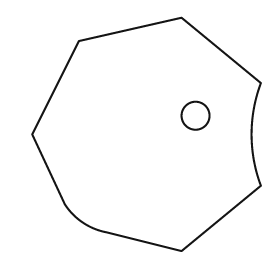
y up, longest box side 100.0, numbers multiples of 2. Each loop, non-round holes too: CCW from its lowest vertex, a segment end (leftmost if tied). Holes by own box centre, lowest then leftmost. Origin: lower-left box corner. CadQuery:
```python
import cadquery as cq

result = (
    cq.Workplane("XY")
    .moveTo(64.0, 0.0)
    .lineTo(98.0, 28.0)
    .threePointArc((94.0, 50.0), (98.0, 72.0))
    .lineTo(64.0, 100.0)
    .lineTo(20.0, 90.0)
    .lineTo(0.0, 50.0)
    .lineTo(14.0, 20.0)
    .threePointArc((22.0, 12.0), (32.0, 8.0))
    .close()
    .moveTo(70.0, 58.0)
    .circle(6.0)
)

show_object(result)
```